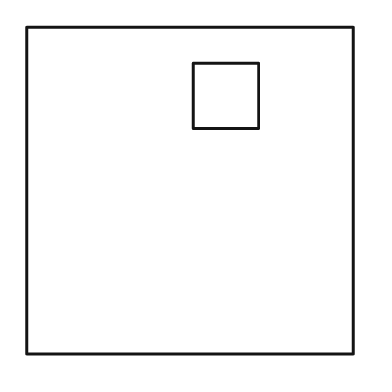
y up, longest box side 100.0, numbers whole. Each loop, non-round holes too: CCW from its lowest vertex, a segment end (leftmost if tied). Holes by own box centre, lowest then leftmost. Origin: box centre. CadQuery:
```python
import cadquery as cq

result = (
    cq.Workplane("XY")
    .moveTo(-50.0, -50.0)
    .lineTo(50.0, -50.0)
    .lineTo(50.0, 50.0)
    .lineTo(-50.0, 50.0)
    .close()
    .moveTo(1.0, 19.0)
    .lineTo(21.0, 19.0)
    .lineTo(21.0, 39.0)
    .lineTo(1.0, 39.0)
    .close()
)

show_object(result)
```